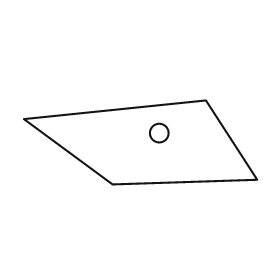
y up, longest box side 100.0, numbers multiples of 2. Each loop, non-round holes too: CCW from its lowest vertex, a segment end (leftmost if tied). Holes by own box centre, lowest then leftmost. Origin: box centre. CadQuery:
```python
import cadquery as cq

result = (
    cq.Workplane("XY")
    .moveTo(-12.0, -18.0)
    .lineTo(50.0, -16.0)
    .lineTo(28.0, 18.0)
    .lineTo(-50.0, 10.0)
    .close()
    .moveTo(8.0, 4.0)
    .circle(4.0)
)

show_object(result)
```